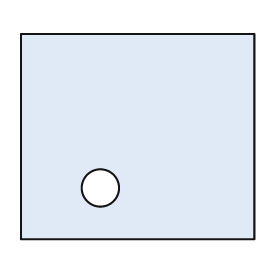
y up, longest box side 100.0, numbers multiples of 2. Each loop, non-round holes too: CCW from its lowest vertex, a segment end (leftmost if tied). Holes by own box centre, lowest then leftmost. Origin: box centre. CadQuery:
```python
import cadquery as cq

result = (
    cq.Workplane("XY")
    .moveTo(-50.0, -44.0)
    .lineTo(50.0, -44.0)
    .lineTo(50.0, 44.0)
    .lineTo(-50.0, 44.0)
    .close()
    .moveTo(-16.0, -22.0)
    .circle(8.0)
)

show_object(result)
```